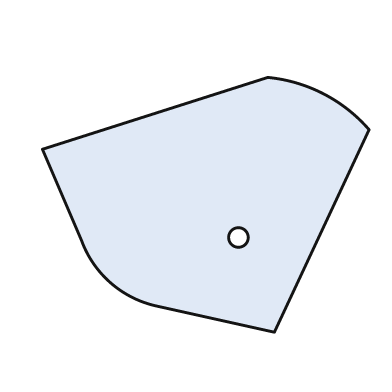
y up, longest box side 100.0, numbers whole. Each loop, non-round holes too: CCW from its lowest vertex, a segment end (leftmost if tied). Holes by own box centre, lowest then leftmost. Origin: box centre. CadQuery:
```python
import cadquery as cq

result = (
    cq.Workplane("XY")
    .moveTo(21.0, -39.0)
    .lineTo(50.0, 23.0)
    .threePointArc((36.0, 34.0), (19.0, 39.0))
    .lineTo(-50.0, 17.0)
    .lineTo(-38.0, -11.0)
    .threePointArc((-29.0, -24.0), (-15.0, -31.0))
    .close()
    .moveTo(10.0, -10.0)
    .circle(3.0)
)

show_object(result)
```